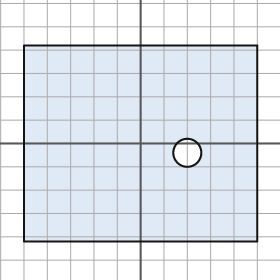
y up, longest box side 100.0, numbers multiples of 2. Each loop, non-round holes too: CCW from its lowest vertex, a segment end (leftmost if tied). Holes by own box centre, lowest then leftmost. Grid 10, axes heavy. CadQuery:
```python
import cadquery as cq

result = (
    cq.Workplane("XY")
    .moveTo(-50.0, -42.0)
    .lineTo(50.0, -42.0)
    .lineTo(50.0, 42.0)
    .lineTo(-50.0, 42.0)
    .close()
    .moveTo(20.0, -4.0)
    .circle(6.0)
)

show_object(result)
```